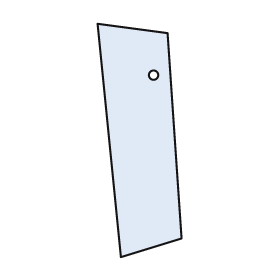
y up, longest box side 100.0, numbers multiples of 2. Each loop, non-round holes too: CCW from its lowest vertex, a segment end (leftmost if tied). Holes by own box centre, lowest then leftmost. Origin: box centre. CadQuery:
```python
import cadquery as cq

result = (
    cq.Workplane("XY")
    .moveTo(-8.0, -50.0)
    .lineTo(18.0, -42.0)
    .lineTo(12.0, 46.0)
    .lineTo(-18.0, 50.0)
    .close()
    .moveTo(6.0, 28.0)
    .circle(2.0)
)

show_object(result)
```